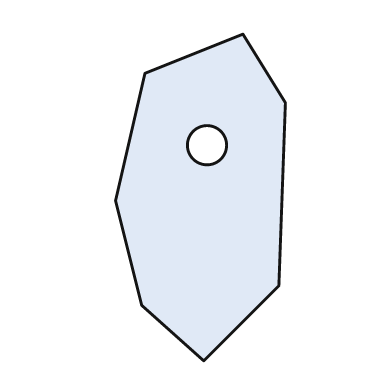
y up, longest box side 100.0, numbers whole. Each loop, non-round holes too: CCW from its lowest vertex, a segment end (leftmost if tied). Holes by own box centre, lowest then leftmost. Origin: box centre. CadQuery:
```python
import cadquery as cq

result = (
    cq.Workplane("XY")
    .moveTo(1.0, -50.0)
    .lineTo(24.0, -27.0)
    .lineTo(26.0, 29.0)
    .lineTo(13.0, 50.0)
    .lineTo(-17.0, 38.0)
    .lineTo(-26.0, -1.0)
    .lineTo(-18.0, -33.0)
    .close()
    .moveTo(2.0, 16.0)
    .circle(6.0)
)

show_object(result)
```